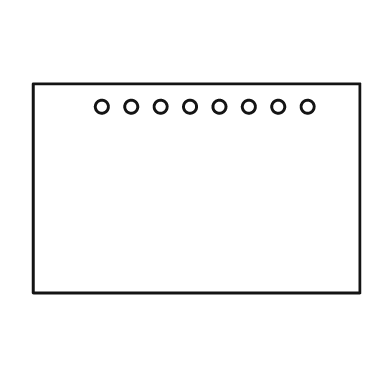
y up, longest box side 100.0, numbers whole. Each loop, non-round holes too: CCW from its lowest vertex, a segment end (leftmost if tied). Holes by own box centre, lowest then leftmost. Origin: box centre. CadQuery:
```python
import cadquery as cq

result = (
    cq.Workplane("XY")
    .moveTo(-50.0, -32.0)
    .lineTo(50.0, -32.0)
    .lineTo(50.0, 32.0)
    .lineTo(-50.0, 32.0)
    .close()
    .moveTo(-29.0, 25.0)
    .circle(2.0)
    .moveTo(-20.0, 25.0)
    .circle(2.0)
    .moveTo(-11.0, 25.0)
    .circle(2.0)
    .moveTo(-2.0, 25.0)
    .circle(2.0)
    .moveTo(7.0, 25.0)
    .circle(2.0)
    .moveTo(16.0, 25.0)
    .circle(2.0)
    .moveTo(25.0, 25.0)
    .circle(2.0)
    .moveTo(34.0, 25.0)
    .circle(2.0)
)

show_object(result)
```